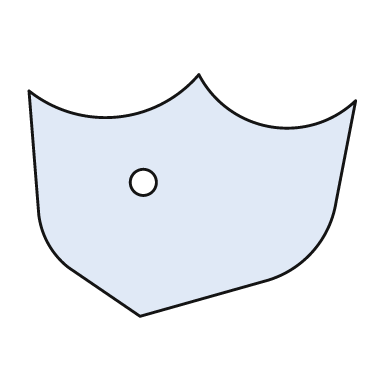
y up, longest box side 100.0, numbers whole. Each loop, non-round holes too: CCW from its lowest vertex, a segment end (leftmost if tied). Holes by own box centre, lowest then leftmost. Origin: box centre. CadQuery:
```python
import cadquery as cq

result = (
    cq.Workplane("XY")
    .moveTo(-16.0, -37.0)
    .lineTo(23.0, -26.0)
    .threePointArc((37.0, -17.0), (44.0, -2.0))
    .lineTo(50.0, 29.0)
    .threePointArc((24.0, 21.0), (2.0, 37.0))
    .threePointArc((-23.0, 24.0), (-50.0, 32.0))
    .lineTo(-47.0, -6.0)
    .threePointArc((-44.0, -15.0), (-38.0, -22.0))
    .close()
    .moveTo(-15.0, 4.0)
    .circle(4.0)
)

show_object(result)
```